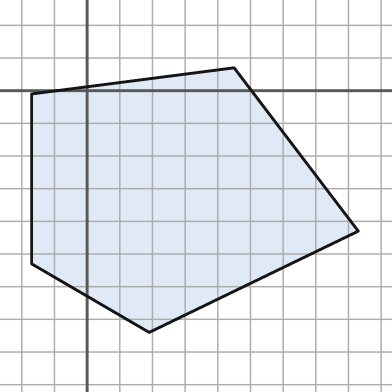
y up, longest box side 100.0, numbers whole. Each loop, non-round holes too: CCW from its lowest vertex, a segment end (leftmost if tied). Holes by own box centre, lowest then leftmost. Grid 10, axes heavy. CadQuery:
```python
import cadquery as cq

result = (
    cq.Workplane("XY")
    .moveTo(19.0, -74.0)
    .lineTo(83.0, -43.0)
    .lineTo(45.0, 7.0)
    .lineTo(-17.0, -1.0)
    .lineTo(-17.0, -53.0)
    .close()
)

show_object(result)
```